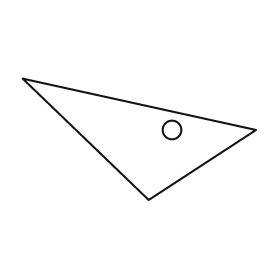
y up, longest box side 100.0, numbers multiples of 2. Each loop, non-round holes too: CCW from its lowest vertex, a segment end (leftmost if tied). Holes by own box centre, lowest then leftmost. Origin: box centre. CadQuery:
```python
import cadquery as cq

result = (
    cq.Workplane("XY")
    .moveTo(4.0, -26.0)
    .lineTo(50.0, 4.0)
    .lineTo(-50.0, 26.0)
    .close()
    .moveTo(14.0, 4.0)
    .circle(4.0)
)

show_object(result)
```